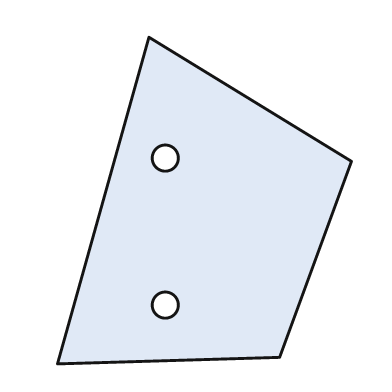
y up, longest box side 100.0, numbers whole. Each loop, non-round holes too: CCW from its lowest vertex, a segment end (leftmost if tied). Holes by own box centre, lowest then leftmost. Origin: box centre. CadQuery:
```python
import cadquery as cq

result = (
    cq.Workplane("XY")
    .moveTo(-45.0, -50.0)
    .lineTo(23.0, -48.0)
    .lineTo(45.0, 12.0)
    .lineTo(-17.0, 50.0)
    .close()
    .moveTo(-12.0, -32.0)
    .circle(4.0)
    .moveTo(-12.0, 13.0)
    .circle(4.0)
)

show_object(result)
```